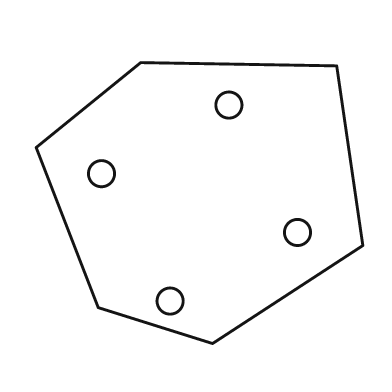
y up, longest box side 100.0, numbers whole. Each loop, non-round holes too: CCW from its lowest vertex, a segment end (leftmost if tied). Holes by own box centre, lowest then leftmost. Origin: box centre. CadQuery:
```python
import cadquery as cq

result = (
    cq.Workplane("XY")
    .moveTo(4.0, -43.0)
    .lineTo(50.0, -13.0)
    .lineTo(42.0, 42.0)
    .lineTo(-18.0, 43.0)
    .lineTo(-50.0, 17.0)
    .lineTo(-31.0, -32.0)
    .close()
    .moveTo(-9.0, -30.0)
    .circle(4.0)
    .moveTo(30.0, -9.0)
    .circle(4.0)
    .moveTo(-30.0, 9.0)
    .circle(4.0)
    .moveTo(9.0, 30.0)
    .circle(4.0)
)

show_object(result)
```